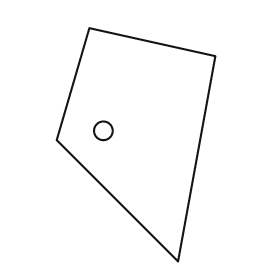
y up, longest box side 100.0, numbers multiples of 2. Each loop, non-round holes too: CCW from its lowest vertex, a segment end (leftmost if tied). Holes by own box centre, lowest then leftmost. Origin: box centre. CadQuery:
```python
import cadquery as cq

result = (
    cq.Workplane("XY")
    .moveTo(18.0, -50.0)
    .lineTo(34.0, 38.0)
    .lineTo(-20.0, 50.0)
    .lineTo(-34.0, 2.0)
    .close()
    .moveTo(-14.0, 6.0)
    .circle(4.0)
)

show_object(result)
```